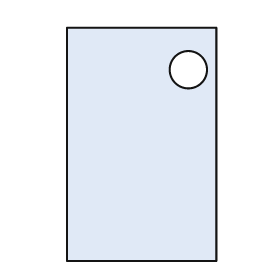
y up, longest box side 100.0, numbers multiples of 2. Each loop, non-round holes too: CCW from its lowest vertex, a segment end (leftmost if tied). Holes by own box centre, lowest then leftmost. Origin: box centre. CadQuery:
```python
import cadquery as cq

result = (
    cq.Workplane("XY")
    .moveTo(-32.0, -50.0)
    .lineTo(32.0, -50.0)
    .lineTo(32.0, 50.0)
    .lineTo(-32.0, 50.0)
    .close()
    .moveTo(20.0, 32.0)
    .circle(8.0)
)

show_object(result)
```